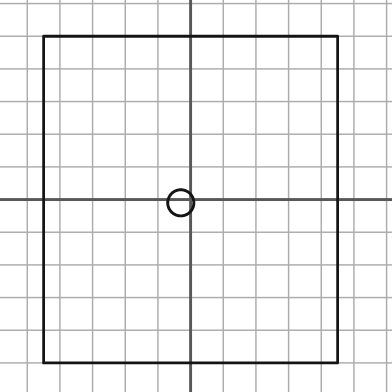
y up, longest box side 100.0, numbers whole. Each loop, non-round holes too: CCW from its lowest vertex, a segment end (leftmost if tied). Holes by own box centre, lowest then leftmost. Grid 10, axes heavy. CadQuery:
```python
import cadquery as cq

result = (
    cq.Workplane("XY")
    .moveTo(-45.0, -50.0)
    .lineTo(45.0, -50.0)
    .lineTo(45.0, 50.0)
    .lineTo(-45.0, 50.0)
    .close()
    .moveTo(-3.0, -1.0)
    .circle(4.0)
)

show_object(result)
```